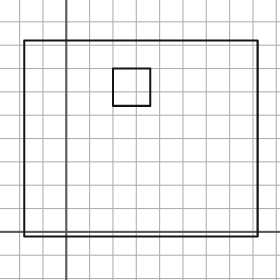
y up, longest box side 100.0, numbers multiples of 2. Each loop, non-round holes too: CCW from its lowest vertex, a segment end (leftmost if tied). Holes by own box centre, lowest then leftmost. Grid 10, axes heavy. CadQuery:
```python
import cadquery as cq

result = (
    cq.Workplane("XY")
    .moveTo(-18.0, -2.0)
    .lineTo(82.0, -2.0)
    .lineTo(82.0, 82.0)
    .lineTo(-18.0, 82.0)
    .close()
    .moveTo(20.0, 54.0)
    .lineTo(36.0, 54.0)
    .lineTo(36.0, 70.0)
    .lineTo(20.0, 70.0)
    .close()
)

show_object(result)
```